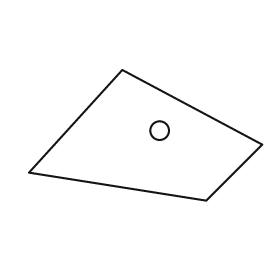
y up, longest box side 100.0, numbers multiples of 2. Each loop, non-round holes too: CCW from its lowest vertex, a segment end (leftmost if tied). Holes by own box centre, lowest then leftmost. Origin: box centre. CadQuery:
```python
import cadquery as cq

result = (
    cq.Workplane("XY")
    .moveTo(26.0, -28.0)
    .lineTo(50.0, -4.0)
    .lineTo(-10.0, 28.0)
    .lineTo(-50.0, -16.0)
    .close()
    .moveTo(6.0, 2.0)
    .circle(4.0)
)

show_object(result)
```